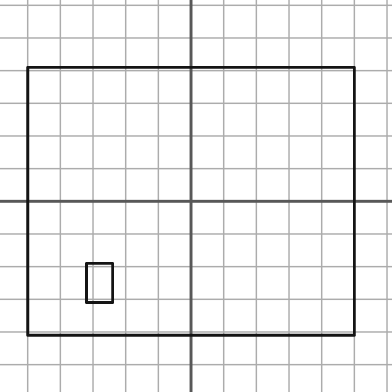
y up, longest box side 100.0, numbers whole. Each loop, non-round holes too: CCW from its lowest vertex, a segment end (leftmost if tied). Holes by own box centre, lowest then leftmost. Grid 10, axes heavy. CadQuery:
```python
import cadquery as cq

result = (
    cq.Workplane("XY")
    .moveTo(-50.0, -41.0)
    .lineTo(50.0, -41.0)
    .lineTo(50.0, 41.0)
    .lineTo(-50.0, 41.0)
    .close()
    .moveTo(-32.0, -31.0)
    .lineTo(-24.0, -31.0)
    .lineTo(-24.0, -19.0)
    .lineTo(-32.0, -19.0)
    .close()
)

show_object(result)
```